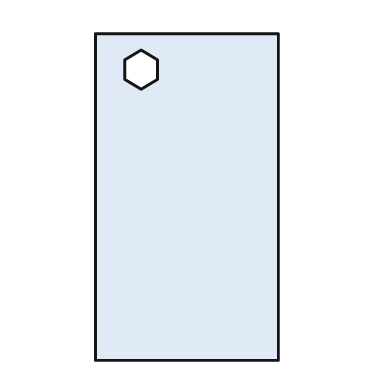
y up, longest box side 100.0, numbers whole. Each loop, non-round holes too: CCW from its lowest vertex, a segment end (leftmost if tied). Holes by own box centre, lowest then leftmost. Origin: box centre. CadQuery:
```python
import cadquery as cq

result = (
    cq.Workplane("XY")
    .moveTo(-28.0, -50.0)
    .lineTo(28.0, -50.0)
    .lineTo(28.0, 50.0)
    .lineTo(-28.0, 50.0)
    .close()
    .moveTo(-14.0, 33.0)
    .lineTo(-9.0, 36.0)
    .lineTo(-9.0, 42.0)
    .lineTo(-14.0, 45.0)
    .lineTo(-19.0, 42.0)
    .lineTo(-19.0, 36.0)
    .close()
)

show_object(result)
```